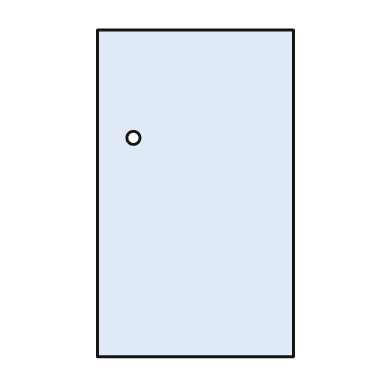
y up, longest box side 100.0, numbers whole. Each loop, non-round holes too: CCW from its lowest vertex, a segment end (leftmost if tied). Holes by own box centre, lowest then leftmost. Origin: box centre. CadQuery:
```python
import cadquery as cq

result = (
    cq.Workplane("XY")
    .moveTo(-30.0, -50.0)
    .lineTo(30.0, -50.0)
    .lineTo(30.0, 50.0)
    .lineTo(-30.0, 50.0)
    .close()
    .moveTo(-19.0, 17.0)
    .circle(2.0)
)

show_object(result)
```